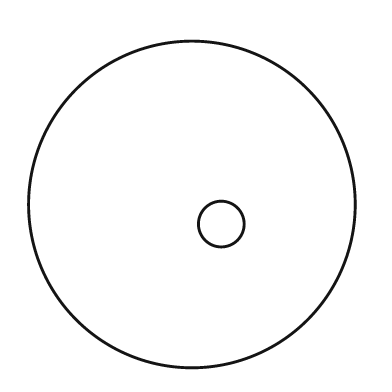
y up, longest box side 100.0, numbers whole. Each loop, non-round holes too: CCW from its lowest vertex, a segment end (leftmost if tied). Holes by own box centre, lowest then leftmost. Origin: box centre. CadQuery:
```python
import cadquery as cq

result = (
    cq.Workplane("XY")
    .moveTo(0.0, 0.0)
    .circle(50.0)
    .moveTo(9.0, -6.0)
    .circle(7.0)
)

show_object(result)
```